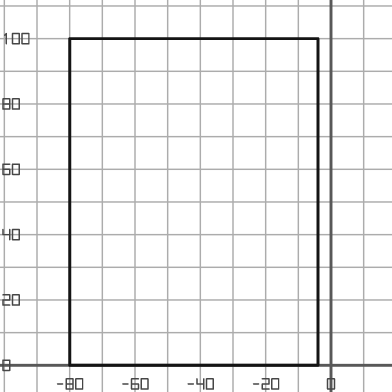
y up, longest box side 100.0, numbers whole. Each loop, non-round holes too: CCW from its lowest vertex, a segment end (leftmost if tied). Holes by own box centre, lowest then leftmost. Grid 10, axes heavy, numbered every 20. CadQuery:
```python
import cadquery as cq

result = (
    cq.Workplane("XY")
    .moveTo(-80.0, 0.0)
    .lineTo(-4.0, 0.0)
    .lineTo(-4.0, 100.0)
    .lineTo(-80.0, 100.0)
    .close()
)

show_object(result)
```